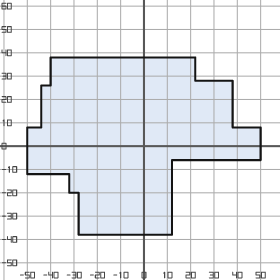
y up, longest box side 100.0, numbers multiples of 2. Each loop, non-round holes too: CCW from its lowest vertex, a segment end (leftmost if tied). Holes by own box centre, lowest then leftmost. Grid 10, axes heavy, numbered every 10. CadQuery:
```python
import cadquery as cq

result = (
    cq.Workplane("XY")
    .moveTo(-28.0, -38.0)
    .lineTo(12.0, -38.0)
    .lineTo(12.0, -6.0)
    .lineTo(50.0, -6.0)
    .lineTo(50.0, 8.0)
    .lineTo(38.0, 8.0)
    .lineTo(38.0, 28.0)
    .lineTo(22.0, 28.0)
    .lineTo(22.0, 38.0)
    .lineTo(-40.0, 38.0)
    .lineTo(-40.0, 26.0)
    .lineTo(-44.0, 26.0)
    .lineTo(-44.0, 8.0)
    .lineTo(-50.0, 8.0)
    .lineTo(-50.0, -12.0)
    .lineTo(-32.0, -12.0)
    .lineTo(-32.0, -20.0)
    .lineTo(-28.0, -20.0)
    .close()
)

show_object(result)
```